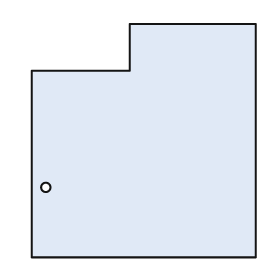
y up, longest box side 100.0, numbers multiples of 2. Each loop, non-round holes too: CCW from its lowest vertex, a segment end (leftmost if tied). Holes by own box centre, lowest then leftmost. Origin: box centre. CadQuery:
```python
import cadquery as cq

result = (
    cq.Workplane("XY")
    .moveTo(-48.0, -50.0)
    .lineTo(48.0, -50.0)
    .lineTo(48.0, 50.0)
    .lineTo(-6.0, 50.0)
    .lineTo(-6.0, 30.0)
    .lineTo(-48.0, 30.0)
    .close()
    .moveTo(-42.0, -20.0)
    .circle(2.0)
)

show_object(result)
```